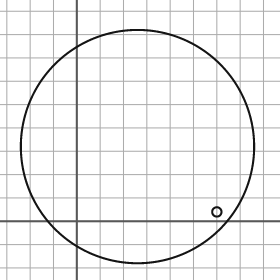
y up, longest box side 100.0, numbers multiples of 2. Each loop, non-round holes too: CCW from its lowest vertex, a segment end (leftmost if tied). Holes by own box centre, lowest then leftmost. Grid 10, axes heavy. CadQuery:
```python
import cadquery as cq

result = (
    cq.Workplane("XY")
    .moveTo(26.0, 32.0)
    .circle(50.0)
    .moveTo(60.0, 4.0)
    .circle(2.0)
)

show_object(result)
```